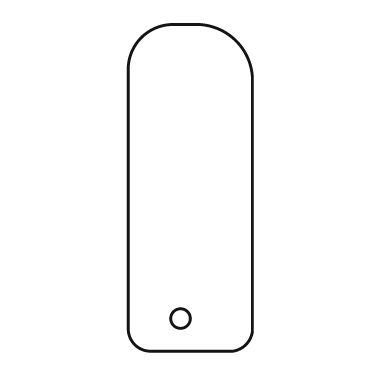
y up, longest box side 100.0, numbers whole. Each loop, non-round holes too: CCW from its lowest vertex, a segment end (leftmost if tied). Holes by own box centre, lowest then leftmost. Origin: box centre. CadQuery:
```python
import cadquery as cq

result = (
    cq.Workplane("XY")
    .moveTo(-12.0, -50.0)
    .lineTo(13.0, -50.0)
    .threePointArc((17.0, -48.0), (19.0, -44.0))
    .lineTo(19.0, 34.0)
    .threePointArc((14.0, 45.0), (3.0, 50.0))
    .lineTo(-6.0, 50.0)
    .threePointArc((-15.0, 46.0), (-19.0, 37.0))
    .lineTo(-19.0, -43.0)
    .threePointArc((-17.0, -48.0), (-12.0, -50.0))
    .close()
    .moveTo(-3.0, -40.0)
    .circle(3.0)
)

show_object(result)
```